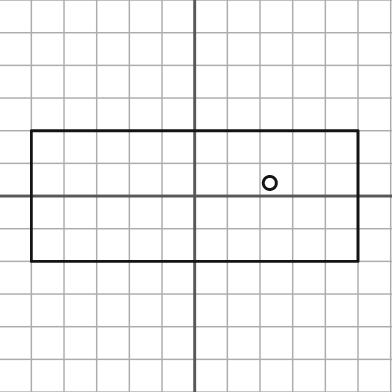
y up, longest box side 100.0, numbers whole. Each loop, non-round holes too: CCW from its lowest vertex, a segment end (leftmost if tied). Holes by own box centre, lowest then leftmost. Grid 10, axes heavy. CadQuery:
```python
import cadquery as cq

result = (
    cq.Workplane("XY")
    .moveTo(-50.0, -20.0)
    .lineTo(50.0, -20.0)
    .lineTo(50.0, 20.0)
    .lineTo(-50.0, 20.0)
    .close()
    .moveTo(23.0, 4.0)
    .circle(2.0)
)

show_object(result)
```